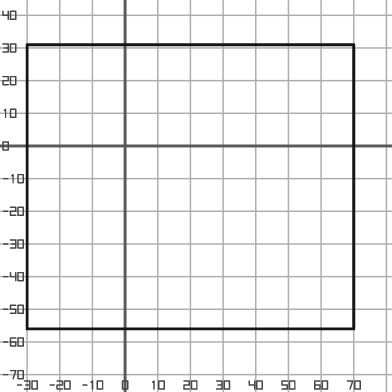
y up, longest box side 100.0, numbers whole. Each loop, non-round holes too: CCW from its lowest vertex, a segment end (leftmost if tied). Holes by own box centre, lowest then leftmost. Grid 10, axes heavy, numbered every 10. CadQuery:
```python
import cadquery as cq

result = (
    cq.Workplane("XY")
    .moveTo(-30.0, -56.0)
    .lineTo(70.0, -56.0)
    .lineTo(70.0, 31.0)
    .lineTo(-30.0, 31.0)
    .close()
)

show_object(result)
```